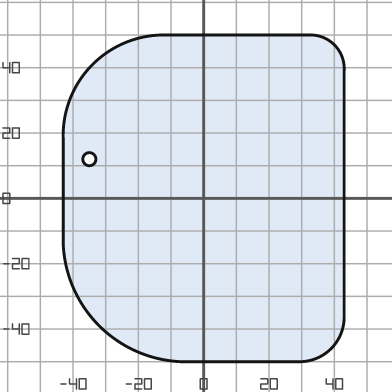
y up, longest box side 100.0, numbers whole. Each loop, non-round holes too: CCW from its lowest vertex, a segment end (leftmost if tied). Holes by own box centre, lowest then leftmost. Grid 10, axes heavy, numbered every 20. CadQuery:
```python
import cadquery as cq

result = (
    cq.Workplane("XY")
    .moveTo(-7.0, -50.0)
    .lineTo(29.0, -50.0)
    .threePointArc((39.0, -46.0), (43.0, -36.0))
    .lineTo(43.0, 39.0)
    .threePointArc((40.0, 47.0), (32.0, 50.0))
    .lineTo(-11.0, 50.0)
    .threePointArc((-34.0, 41.0), (-43.0, 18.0))
    .lineTo(-43.0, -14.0)
    .threePointArc((-32.0, -39.0), (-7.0, -50.0))
    .close()
    .moveTo(-35.0, 12.0)
    .circle(2.0)
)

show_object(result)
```